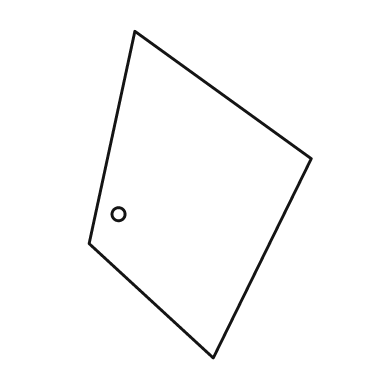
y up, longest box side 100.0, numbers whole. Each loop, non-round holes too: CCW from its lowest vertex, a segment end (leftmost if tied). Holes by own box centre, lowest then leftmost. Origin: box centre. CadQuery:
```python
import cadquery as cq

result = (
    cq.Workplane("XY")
    .moveTo(4.0, -50.0)
    .lineTo(34.0, 11.0)
    .lineTo(-20.0, 50.0)
    .lineTo(-34.0, -15.0)
    .close()
    .moveTo(-25.0, -6.0)
    .circle(2.0)
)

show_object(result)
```